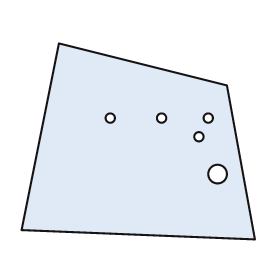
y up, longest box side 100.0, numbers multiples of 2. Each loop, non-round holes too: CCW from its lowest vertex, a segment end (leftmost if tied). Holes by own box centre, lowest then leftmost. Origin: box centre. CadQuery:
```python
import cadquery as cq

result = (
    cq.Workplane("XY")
    .moveTo(50.0, -42.0)
    .lineTo(38.0, 24.0)
    .lineTo(-34.0, 42.0)
    .lineTo(-50.0, -38.0)
    .close()
    .moveTo(34.0, -14.0)
    .circle(4.0)
    .moveTo(26.0, 2.0)
    .circle(2.0)
    .moveTo(-12.0, 10.0)
    .circle(2.0)
    .moveTo(10.0, 10.0)
    .circle(2.0)
    .moveTo(30.0, 10.0)
    .circle(2.0)
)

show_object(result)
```